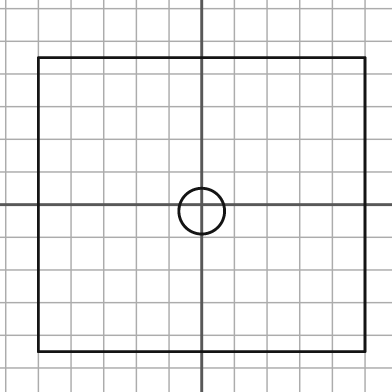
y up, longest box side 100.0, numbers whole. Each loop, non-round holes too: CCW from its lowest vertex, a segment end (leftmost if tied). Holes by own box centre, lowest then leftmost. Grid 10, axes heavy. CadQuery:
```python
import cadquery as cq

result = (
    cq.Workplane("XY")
    .moveTo(-50.0, -45.0)
    .lineTo(50.0, -45.0)
    .lineTo(50.0, 45.0)
    .lineTo(-50.0, 45.0)
    .close()
    .moveTo(0.0, -2.0)
    .circle(7.0)
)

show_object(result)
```